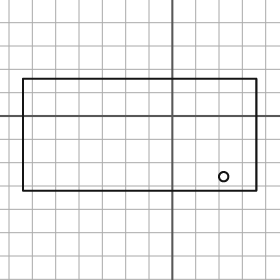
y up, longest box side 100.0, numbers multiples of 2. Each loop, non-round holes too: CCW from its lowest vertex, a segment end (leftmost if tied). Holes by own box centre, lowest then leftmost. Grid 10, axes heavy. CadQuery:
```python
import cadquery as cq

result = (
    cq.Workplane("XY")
    .moveTo(-64.0, -32.0)
    .lineTo(36.0, -32.0)
    .lineTo(36.0, 16.0)
    .lineTo(-64.0, 16.0)
    .close()
    .moveTo(22.0, -26.0)
    .circle(2.0)
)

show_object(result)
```